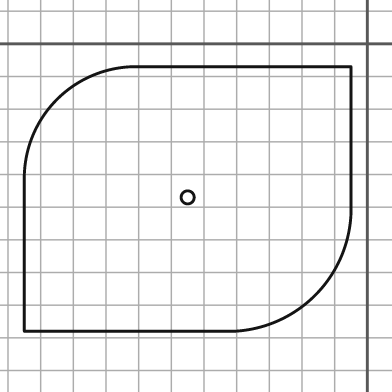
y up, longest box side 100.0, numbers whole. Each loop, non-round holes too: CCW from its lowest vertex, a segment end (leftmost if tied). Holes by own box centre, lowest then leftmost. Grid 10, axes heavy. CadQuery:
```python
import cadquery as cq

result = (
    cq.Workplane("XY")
    .moveTo(-105.0, -88.0)
    .lineTo(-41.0, -88.0)
    .threePointArc((-16.0, -77.0), (-5.0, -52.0))
    .lineTo(-5.0, -7.0)
    .lineTo(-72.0, -7.0)
    .threePointArc((-95.0, -17.0), (-105.0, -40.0))
    .close()
    .moveTo(-55.0, -47.0)
    .circle(2.0)
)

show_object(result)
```